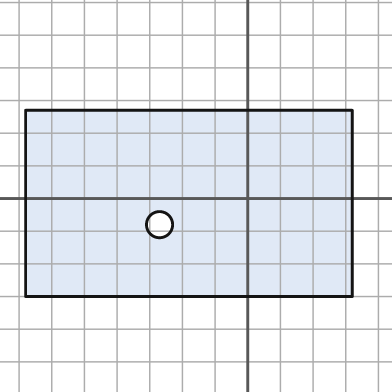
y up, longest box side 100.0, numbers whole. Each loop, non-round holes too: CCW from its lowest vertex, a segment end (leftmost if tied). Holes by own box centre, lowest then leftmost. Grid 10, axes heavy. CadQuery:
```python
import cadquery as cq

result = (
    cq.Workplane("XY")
    .moveTo(-68.0, -30.0)
    .lineTo(32.0, -30.0)
    .lineTo(32.0, 27.0)
    .lineTo(-68.0, 27.0)
    .close()
    .moveTo(-27.0, -8.0)
    .circle(4.0)
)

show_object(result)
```